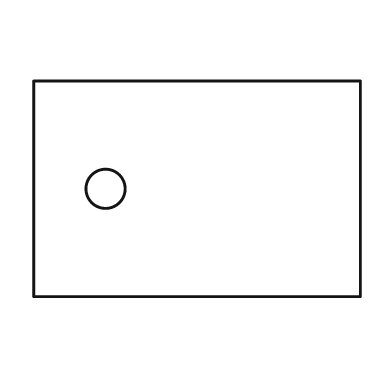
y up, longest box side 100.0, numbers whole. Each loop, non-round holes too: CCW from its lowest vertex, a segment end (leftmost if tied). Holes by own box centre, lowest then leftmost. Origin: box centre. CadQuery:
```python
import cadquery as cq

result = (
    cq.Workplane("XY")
    .moveTo(-50.0, -33.0)
    .lineTo(50.0, -33.0)
    .lineTo(50.0, 33.0)
    .lineTo(-50.0, 33.0)
    .close()
    .moveTo(-28.0, 0.0)
    .circle(6.0)
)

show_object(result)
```